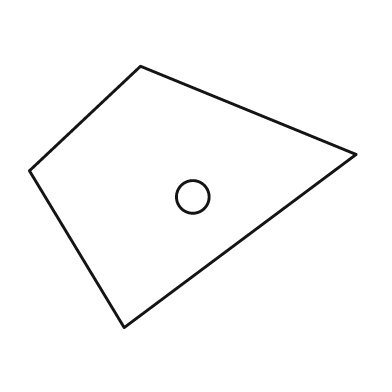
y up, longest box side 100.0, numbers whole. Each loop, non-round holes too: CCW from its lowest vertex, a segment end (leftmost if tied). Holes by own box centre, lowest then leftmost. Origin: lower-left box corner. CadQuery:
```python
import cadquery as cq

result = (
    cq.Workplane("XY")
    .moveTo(29.0, 0.0)
    .lineTo(100.0, 53.0)
    .lineTo(34.0, 80.0)
    .lineTo(0.0, 48.0)
    .close()
    .moveTo(50.0, 40.0)
    .circle(5.0)
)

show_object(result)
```